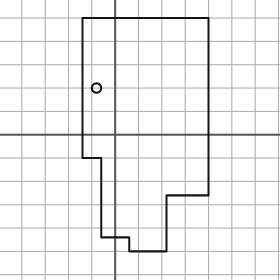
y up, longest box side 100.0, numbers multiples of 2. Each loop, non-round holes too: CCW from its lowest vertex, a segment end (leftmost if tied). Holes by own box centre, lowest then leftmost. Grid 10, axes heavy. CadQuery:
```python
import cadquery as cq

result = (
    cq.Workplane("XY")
    .moveTo(6.0, -50.0)
    .lineTo(22.0, -50.0)
    .lineTo(22.0, -26.0)
    .lineTo(40.0, -26.0)
    .lineTo(40.0, 50.0)
    .lineTo(-14.0, 50.0)
    .lineTo(-14.0, -10.0)
    .lineTo(-6.0, -10.0)
    .lineTo(-6.0, -44.0)
    .lineTo(6.0, -44.0)
    .close()
    .moveTo(-8.0, 20.0)
    .circle(2.0)
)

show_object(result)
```